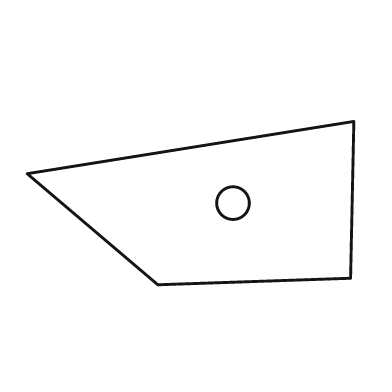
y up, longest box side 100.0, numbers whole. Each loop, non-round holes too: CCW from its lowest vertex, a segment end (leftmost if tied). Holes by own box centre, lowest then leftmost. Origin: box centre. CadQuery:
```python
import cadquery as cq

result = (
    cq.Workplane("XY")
    .moveTo(-10.0, -25.0)
    .lineTo(49.0, -23.0)
    .lineTo(50.0, 25.0)
    .lineTo(-50.0, 9.0)
    .close()
    .moveTo(13.0, 0.0)
    .circle(5.0)
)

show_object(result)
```